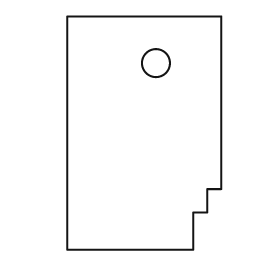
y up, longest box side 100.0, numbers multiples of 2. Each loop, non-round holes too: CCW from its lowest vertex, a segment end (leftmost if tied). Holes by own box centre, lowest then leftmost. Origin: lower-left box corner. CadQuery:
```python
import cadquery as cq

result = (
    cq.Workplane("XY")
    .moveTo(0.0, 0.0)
    .lineTo(54.0, 0.0)
    .lineTo(54.0, 16.0)
    .lineTo(60.0, 16.0)
    .lineTo(60.0, 26.0)
    .lineTo(66.0, 26.0)
    .lineTo(66.0, 100.0)
    .lineTo(0.0, 100.0)
    .close()
    .moveTo(38.0, 80.0)
    .circle(6.0)
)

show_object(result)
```